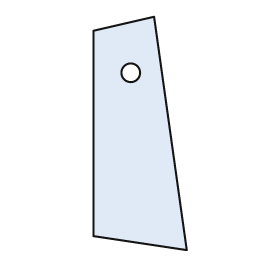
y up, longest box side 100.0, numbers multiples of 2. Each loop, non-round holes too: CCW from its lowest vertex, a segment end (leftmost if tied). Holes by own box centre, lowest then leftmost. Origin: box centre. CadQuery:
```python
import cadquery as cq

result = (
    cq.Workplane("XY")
    .moveTo(20.0, -50.0)
    .lineTo(6.0, 50.0)
    .lineTo(-20.0, 44.0)
    .lineTo(-20.0, -44.0)
    .close()
    .moveTo(-4.0, 26.0)
    .circle(4.0)
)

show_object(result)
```